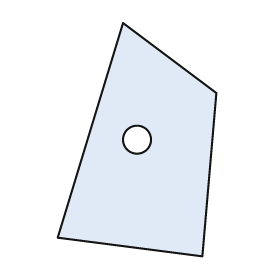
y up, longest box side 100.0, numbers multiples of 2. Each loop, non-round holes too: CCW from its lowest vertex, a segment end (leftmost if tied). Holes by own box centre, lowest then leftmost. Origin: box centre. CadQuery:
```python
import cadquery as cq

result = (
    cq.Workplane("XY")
    .moveTo(28.0, -50.0)
    .lineTo(34.0, 20.0)
    .lineTo(-6.0, 50.0)
    .lineTo(-34.0, -42.0)
    .close()
    .moveTo(0.0, 0.0)
    .circle(6.0)
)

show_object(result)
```